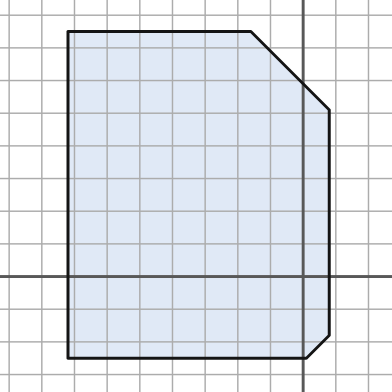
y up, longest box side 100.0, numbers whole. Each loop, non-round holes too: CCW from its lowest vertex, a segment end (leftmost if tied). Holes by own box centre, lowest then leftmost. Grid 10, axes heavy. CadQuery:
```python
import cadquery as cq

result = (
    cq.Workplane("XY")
    .moveTo(-72.0, -25.0)
    .lineTo(1.0, -25.0)
    .lineTo(8.0, -18.0)
    .lineTo(8.0, 51.0)
    .lineTo(-16.0, 75.0)
    .lineTo(-72.0, 75.0)
    .close()
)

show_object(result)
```